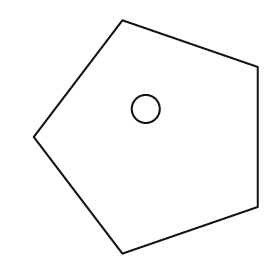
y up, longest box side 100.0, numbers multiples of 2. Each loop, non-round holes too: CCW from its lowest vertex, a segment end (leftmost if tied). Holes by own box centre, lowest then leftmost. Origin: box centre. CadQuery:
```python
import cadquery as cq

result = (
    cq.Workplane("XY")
    .moveTo(-10.0, -50.0)
    .lineTo(48.0, -30.0)
    .lineTo(48.0, 30.0)
    .lineTo(-10.0, 50.0)
    .lineTo(-48.0, 0.0)
    .close()
    .moveTo(0.0, 12.0)
    .circle(6.0)
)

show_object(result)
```